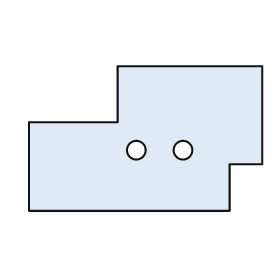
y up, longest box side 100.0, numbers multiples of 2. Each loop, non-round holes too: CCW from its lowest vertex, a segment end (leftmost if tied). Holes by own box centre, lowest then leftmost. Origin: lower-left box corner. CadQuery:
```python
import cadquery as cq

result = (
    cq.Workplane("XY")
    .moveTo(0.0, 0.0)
    .lineTo(86.0, 0.0)
    .lineTo(86.0, 20.0)
    .lineTo(100.0, 20.0)
    .lineTo(100.0, 62.0)
    .lineTo(38.0, 62.0)
    .lineTo(38.0, 38.0)
    .lineTo(0.0, 38.0)
    .close()
    .moveTo(46.0, 26.0)
    .circle(4.0)
    .moveTo(66.0, 26.0)
    .circle(4.0)
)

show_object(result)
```